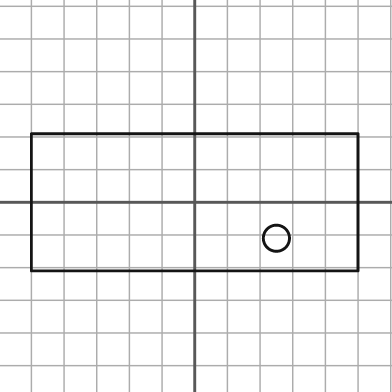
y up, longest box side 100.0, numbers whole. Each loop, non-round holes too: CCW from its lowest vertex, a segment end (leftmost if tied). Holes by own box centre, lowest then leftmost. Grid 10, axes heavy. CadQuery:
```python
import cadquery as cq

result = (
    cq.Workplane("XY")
    .moveTo(-50.0, -21.0)
    .lineTo(50.0, -21.0)
    .lineTo(50.0, 21.0)
    .lineTo(-50.0, 21.0)
    .close()
    .moveTo(25.0, -11.0)
    .circle(4.0)
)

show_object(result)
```